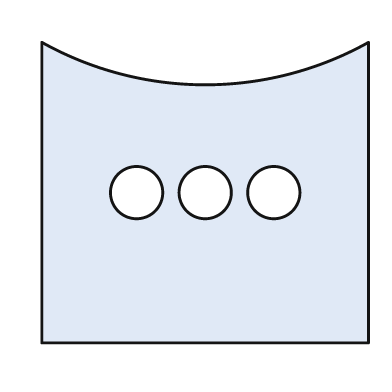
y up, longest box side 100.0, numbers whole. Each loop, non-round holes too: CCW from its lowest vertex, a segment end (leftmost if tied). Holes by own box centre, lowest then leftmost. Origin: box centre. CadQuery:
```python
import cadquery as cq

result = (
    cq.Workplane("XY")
    .moveTo(-50.0, -46.0)
    .lineTo(50.0, -46.0)
    .lineTo(50.0, 46.0)
    .threePointArc((0.0, 33.0), (-50.0, 46.0))
    .close()
    .moveTo(-21.0, 0.0)
    .circle(8.0)
    .moveTo(0.0, 0.0)
    .circle(8.0)
    .moveTo(21.0, 0.0)
    .circle(8.0)
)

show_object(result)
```